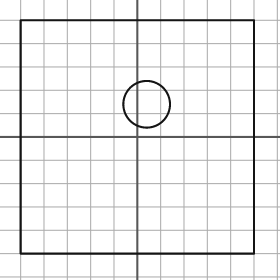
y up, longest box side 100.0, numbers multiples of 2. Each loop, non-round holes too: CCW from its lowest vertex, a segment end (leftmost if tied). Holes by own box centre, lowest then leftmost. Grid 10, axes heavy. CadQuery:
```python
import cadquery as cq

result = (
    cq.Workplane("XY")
    .moveTo(-50.0, -50.0)
    .lineTo(50.0, -50.0)
    .lineTo(50.0, 50.0)
    .lineTo(-50.0, 50.0)
    .close()
    .moveTo(4.0, 14.0)
    .circle(10.0)
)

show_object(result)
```